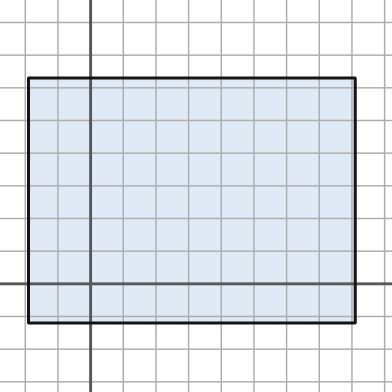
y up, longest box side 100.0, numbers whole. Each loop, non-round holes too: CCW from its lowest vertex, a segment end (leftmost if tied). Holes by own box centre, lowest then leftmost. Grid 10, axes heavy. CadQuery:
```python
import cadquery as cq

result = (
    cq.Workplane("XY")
    .moveTo(-19.0, -12.0)
    .lineTo(81.0, -12.0)
    .lineTo(81.0, 63.0)
    .lineTo(-19.0, 63.0)
    .close()
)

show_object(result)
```